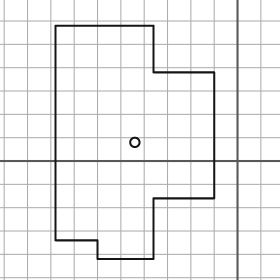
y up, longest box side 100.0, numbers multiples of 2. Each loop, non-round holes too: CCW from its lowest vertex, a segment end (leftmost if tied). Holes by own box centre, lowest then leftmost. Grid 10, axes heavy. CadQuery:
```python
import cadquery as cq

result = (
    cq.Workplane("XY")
    .moveTo(-60.0, -42.0)
    .lineTo(-36.0, -42.0)
    .lineTo(-36.0, -16.0)
    .lineTo(-10.0, -16.0)
    .lineTo(-10.0, 38.0)
    .lineTo(-36.0, 38.0)
    .lineTo(-36.0, 58.0)
    .lineTo(-78.0, 58.0)
    .lineTo(-78.0, -34.0)
    .lineTo(-60.0, -34.0)
    .close()
    .moveTo(-44.0, 8.0)
    .circle(2.0)
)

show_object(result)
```